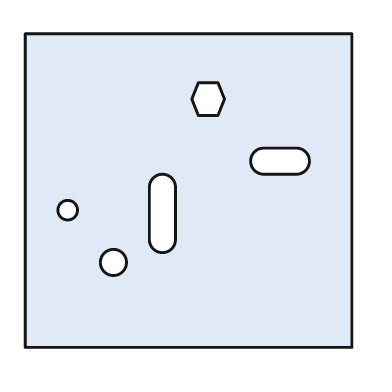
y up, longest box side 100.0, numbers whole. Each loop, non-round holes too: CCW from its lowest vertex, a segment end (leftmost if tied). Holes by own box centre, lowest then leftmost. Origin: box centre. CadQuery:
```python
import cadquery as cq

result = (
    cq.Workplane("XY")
    .moveTo(-50.0, -48.0)
    .lineTo(50.0, -48.0)
    .lineTo(50.0, 48.0)
    .lineTo(-50.0, 48.0)
    .close()
    .moveTo(-23.0, -22.0)
    .circle(4.0)
    .moveTo(-12.0, -15.0)
    .threePointArc((-8.0, -19.0), (-4.0, -15.0))
    .lineTo(-4.0, 1.0)
    .threePointArc((-8.0, 5.0), (-12.0, 1.0))
    .close()
    .moveTo(-37.0, -6.0)
    .circle(3.0)
    .moveTo(23.0, 5.0)
    .lineTo(33.0, 5.0)
    .threePointArc((37.0, 9.0), (33.0, 13.0))
    .lineTo(23.0, 13.0)
    .threePointArc((19.0, 9.0), (23.0, 5.0))
    .close()
    .moveTo(3.0, 23.0)
    .lineTo(9.0, 23.0)
    .lineTo(11.0, 28.0)
    .lineTo(9.0, 33.0)
    .lineTo(3.0, 33.0)
    .lineTo(1.0, 28.0)
    .close()
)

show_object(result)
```